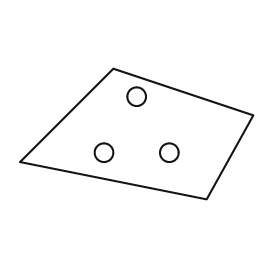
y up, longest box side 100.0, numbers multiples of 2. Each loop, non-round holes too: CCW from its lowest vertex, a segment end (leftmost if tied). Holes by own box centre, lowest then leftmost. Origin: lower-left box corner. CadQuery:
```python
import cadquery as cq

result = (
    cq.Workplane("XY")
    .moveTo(80.0, 0.0)
    .lineTo(100.0, 36.0)
    .lineTo(40.0, 56.0)
    .lineTo(0.0, 16.0)
    .close()
    .moveTo(36.0, 20.0)
    .circle(4.0)
    .moveTo(64.0, 20.0)
    .circle(4.0)
    .moveTo(50.0, 44.0)
    .circle(4.0)
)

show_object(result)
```